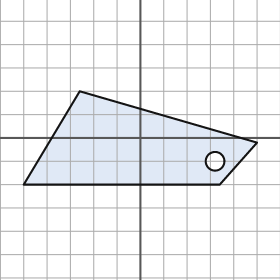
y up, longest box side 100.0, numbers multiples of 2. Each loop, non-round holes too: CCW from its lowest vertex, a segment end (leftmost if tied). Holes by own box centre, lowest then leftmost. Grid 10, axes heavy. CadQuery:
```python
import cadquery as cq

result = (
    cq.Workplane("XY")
    .moveTo(-50.0, -20.0)
    .lineTo(34.0, -20.0)
    .lineTo(50.0, -2.0)
    .lineTo(-26.0, 20.0)
    .close()
    .moveTo(32.0, -10.0)
    .circle(4.0)
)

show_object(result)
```